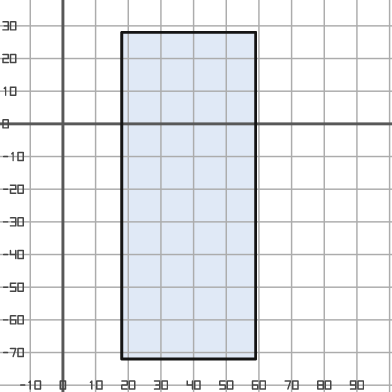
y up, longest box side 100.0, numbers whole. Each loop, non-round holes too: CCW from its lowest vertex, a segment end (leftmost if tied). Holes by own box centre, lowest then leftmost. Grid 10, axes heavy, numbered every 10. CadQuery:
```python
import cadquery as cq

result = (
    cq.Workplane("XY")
    .moveTo(18.0, -72.0)
    .lineTo(59.0, -72.0)
    .lineTo(59.0, 28.0)
    .lineTo(18.0, 28.0)
    .close()
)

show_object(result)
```